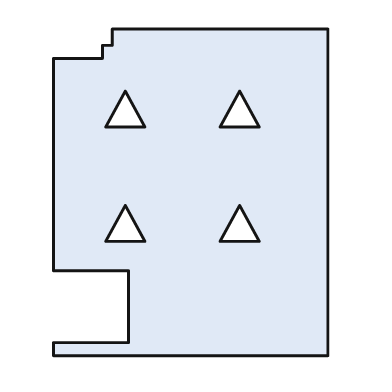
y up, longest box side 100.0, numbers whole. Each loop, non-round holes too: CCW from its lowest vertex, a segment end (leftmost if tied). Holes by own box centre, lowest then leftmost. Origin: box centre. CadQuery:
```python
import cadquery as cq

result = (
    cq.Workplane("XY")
    .moveTo(-42.0, -50.0)
    .lineTo(42.0, -50.0)
    .lineTo(42.0, 50.0)
    .lineTo(-24.0, 50.0)
    .lineTo(-24.0, 45.0)
    .lineTo(-27.0, 45.0)
    .lineTo(-27.0, 41.0)
    .lineTo(-42.0, 41.0)
    .lineTo(-42.0, -24.0)
    .lineTo(-19.0, -24.0)
    .lineTo(-19.0, -46.0)
    .lineTo(-42.0, -46.0)
    .close()
    .moveTo(-26.0, -15.0)
    .lineTo(-14.0, -15.0)
    .lineTo(-20.0, -4.0)
    .close()
    .moveTo(9.0, -15.0)
    .lineTo(21.0, -15.0)
    .lineTo(15.0, -4.0)
    .close()
    .moveTo(-26.0, 20.0)
    .lineTo(-14.0, 20.0)
    .lineTo(-20.0, 31.0)
    .close()
    .moveTo(9.0, 20.0)
    .lineTo(21.0, 20.0)
    .lineTo(15.0, 31.0)
    .close()
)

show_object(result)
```